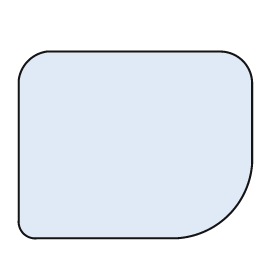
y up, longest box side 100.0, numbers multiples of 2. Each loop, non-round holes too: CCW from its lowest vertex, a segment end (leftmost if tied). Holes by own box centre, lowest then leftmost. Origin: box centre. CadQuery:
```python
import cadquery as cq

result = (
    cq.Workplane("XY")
    .moveTo(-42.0, -40.0)
    .lineTo(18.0, -40.0)
    .threePointArc((40.0, -30.0), (50.0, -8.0))
    .lineTo(50.0, 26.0)
    .threePointArc((46.0, 36.0), (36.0, 40.0))
    .lineTo(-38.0, 40.0)
    .threePointArc((-46.0, 36.0), (-50.0, 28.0))
    .lineTo(-50.0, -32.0)
    .threePointArc((-48.0, -38.0), (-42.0, -40.0))
    .close()
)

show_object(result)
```